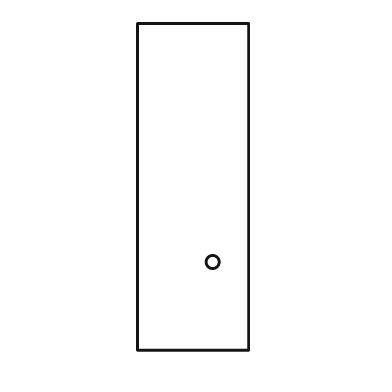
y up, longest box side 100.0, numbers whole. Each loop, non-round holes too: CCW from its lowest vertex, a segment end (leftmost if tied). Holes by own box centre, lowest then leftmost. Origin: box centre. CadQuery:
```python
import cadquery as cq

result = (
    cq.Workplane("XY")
    .moveTo(-17.0, -50.0)
    .lineTo(17.0, -50.0)
    .lineTo(17.0, 50.0)
    .lineTo(-17.0, 50.0)
    .close()
    .moveTo(6.0, -23.0)
    .circle(2.0)
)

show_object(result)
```